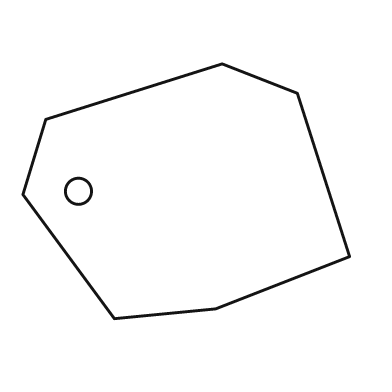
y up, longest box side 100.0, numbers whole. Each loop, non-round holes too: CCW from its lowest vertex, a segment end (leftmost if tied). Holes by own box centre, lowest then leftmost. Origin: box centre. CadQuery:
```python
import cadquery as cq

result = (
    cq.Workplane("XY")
    .moveTo(-22.0, -39.0)
    .lineTo(9.0, -36.0)
    .lineTo(50.0, -20.0)
    .lineTo(34.0, 30.0)
    .lineTo(11.0, 39.0)
    .lineTo(-43.0, 22.0)
    .lineTo(-50.0, -1.0)
    .close()
    .moveTo(-33.0, 0.0)
    .circle(4.0)
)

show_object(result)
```